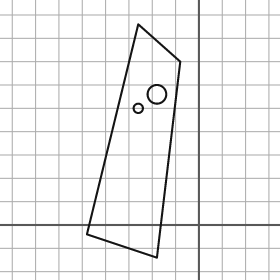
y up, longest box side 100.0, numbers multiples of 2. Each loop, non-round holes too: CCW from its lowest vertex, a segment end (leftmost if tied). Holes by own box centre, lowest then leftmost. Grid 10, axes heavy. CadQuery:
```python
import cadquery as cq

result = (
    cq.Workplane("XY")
    .moveTo(-18.0, -14.0)
    .lineTo(-8.0, 70.0)
    .lineTo(-26.0, 86.0)
    .lineTo(-48.0, -4.0)
    .close()
    .moveTo(-26.0, 50.0)
    .circle(2.0)
    .moveTo(-18.0, 56.0)
    .circle(4.0)
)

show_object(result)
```